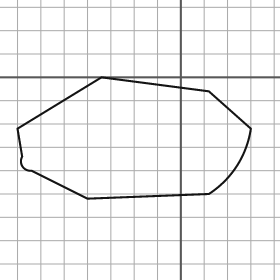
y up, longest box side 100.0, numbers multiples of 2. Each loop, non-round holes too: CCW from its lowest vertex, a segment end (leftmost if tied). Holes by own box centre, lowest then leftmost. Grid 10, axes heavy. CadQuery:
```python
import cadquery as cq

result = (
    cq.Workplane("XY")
    .moveTo(-40.0, -52.0)
    .lineTo(12.0, -50.0)
    .threePointArc((24.0, -38.0), (30.0, -22.0))
    .lineTo(12.0, -6.0)
    .lineTo(-34.0, 0.0)
    .lineTo(-70.0, -22.0)
    .lineTo(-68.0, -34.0)
    .threePointArc((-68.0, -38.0), (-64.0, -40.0))
    .close()
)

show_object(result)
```